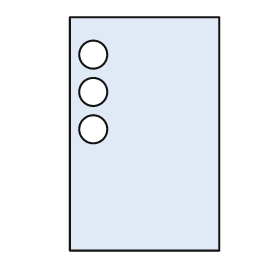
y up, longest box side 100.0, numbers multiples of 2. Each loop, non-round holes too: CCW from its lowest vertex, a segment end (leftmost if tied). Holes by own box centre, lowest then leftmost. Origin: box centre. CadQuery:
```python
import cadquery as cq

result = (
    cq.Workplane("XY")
    .moveTo(-32.0, -50.0)
    .lineTo(32.0, -50.0)
    .lineTo(32.0, 50.0)
    .lineTo(-32.0, 50.0)
    .close()
    .moveTo(-22.0, 2.0)
    .circle(6.0)
    .moveTo(-22.0, 18.0)
    .circle(6.0)
    .moveTo(-22.0, 34.0)
    .circle(6.0)
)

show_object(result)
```